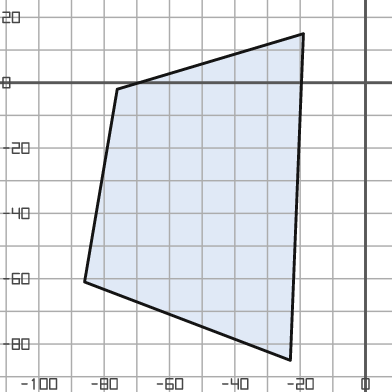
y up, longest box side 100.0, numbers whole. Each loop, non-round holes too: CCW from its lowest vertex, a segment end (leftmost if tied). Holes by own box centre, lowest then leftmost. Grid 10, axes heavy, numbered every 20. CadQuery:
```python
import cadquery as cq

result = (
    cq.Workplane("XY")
    .moveTo(-23.0, -85.0)
    .lineTo(-19.0, 15.0)
    .lineTo(-76.0, -2.0)
    .lineTo(-86.0, -61.0)
    .close()
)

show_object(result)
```